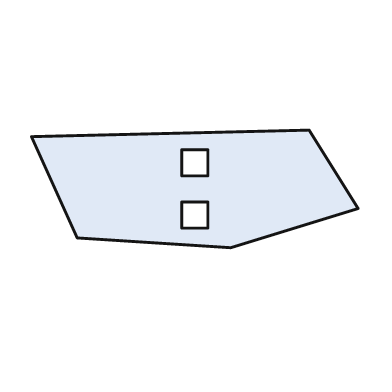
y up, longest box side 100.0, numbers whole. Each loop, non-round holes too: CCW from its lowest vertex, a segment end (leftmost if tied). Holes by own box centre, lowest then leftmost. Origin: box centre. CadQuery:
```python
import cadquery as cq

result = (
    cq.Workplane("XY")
    .moveTo(11.0, -18.0)
    .lineTo(50.0, -6.0)
    .lineTo(35.0, 18.0)
    .lineTo(-50.0, 16.0)
    .lineTo(-36.0, -15.0)
    .close()
    .moveTo(-4.0, -12.0)
    .lineTo(4.0, -12.0)
    .lineTo(4.0, -4.0)
    .lineTo(-4.0, -4.0)
    .close()
    .moveTo(-4.0, 4.0)
    .lineTo(4.0, 4.0)
    .lineTo(4.0, 12.0)
    .lineTo(-4.0, 12.0)
    .close()
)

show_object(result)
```